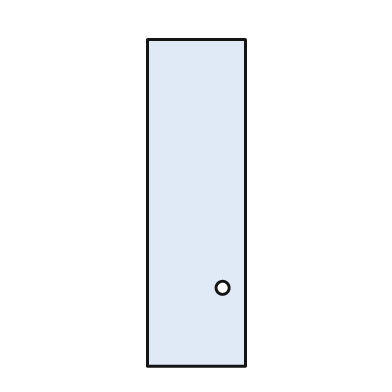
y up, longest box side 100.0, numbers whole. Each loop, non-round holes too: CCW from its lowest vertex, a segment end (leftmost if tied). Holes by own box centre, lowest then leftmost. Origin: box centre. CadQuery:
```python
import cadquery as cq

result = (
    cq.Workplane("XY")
    .moveTo(-15.0, -50.0)
    .lineTo(15.0, -50.0)
    .lineTo(15.0, 50.0)
    .lineTo(-15.0, 50.0)
    .close()
    .moveTo(8.0, -26.0)
    .circle(2.0)
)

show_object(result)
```